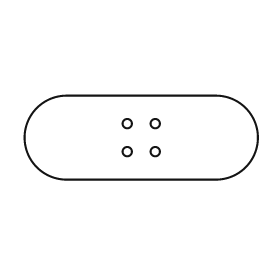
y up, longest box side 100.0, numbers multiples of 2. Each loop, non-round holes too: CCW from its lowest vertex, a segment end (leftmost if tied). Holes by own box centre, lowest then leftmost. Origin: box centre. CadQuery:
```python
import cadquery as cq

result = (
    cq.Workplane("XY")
    .moveTo(-32.0, -18.0)
    .lineTo(32.0, -18.0)
    .threePointArc((50.0, 0.0), (32.0, 18.0))
    .lineTo(-32.0, 18.0)
    .threePointArc((-50.0, 0.0), (-32.0, -18.0))
    .close()
    .moveTo(-6.0, -6.0)
    .circle(2.0)
    .moveTo(6.0, -6.0)
    .circle(2.0)
    .moveTo(-6.0, 6.0)
    .circle(2.0)
    .moveTo(6.0, 6.0)
    .circle(2.0)
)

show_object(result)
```